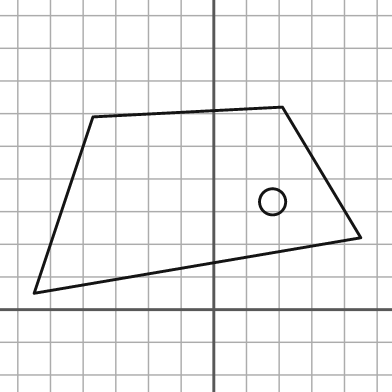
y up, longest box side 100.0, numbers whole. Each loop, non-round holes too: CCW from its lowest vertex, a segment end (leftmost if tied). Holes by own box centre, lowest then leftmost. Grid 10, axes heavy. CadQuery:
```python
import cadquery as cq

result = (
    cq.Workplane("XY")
    .moveTo(-55.0, 5.0)
    .lineTo(45.0, 22.0)
    .lineTo(21.0, 62.0)
    .lineTo(-37.0, 59.0)
    .close()
    .moveTo(18.0, 33.0)
    .circle(4.0)
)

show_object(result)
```